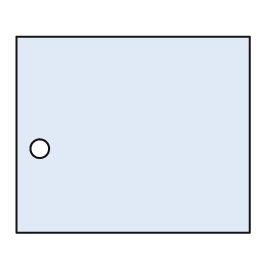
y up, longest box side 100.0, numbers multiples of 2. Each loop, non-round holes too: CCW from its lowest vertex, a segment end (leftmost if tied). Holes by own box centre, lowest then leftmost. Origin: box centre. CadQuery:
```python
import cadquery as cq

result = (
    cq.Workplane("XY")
    .moveTo(-50.0, -42.0)
    .lineTo(50.0, -42.0)
    .lineTo(50.0, 42.0)
    .lineTo(-50.0, 42.0)
    .close()
    .moveTo(-40.0, -6.0)
    .circle(4.0)
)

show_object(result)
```